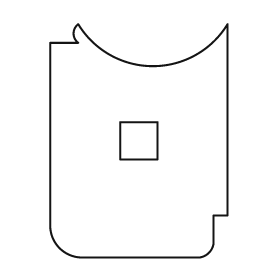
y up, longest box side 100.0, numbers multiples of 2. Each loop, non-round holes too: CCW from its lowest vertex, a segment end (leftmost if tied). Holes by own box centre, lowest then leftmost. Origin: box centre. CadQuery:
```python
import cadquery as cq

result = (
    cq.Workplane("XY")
    .moveTo(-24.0, -50.0)
    .lineTo(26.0, -50.0)
    .threePointArc((30.0, -48.0), (32.0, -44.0))
    .lineTo(32.0, -32.0)
    .lineTo(38.0, -32.0)
    .lineTo(38.0, 50.0)
    .threePointArc((6.0, 32.0), (-26.0, 50.0))
    .threePointArc((-28.0, 46.0), (-26.0, 42.0))
    .lineTo(-38.0, 42.0)
    .lineTo(-38.0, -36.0)
    .threePointArc((-34.0, -46.0), (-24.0, -50.0))
    .close()
    .moveTo(-8.0, -8.0)
    .lineTo(8.0, -8.0)
    .lineTo(8.0, 8.0)
    .lineTo(-8.0, 8.0)
    .close()
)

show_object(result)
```